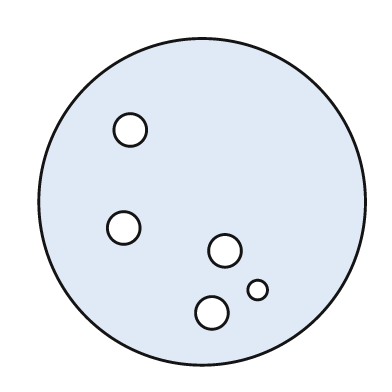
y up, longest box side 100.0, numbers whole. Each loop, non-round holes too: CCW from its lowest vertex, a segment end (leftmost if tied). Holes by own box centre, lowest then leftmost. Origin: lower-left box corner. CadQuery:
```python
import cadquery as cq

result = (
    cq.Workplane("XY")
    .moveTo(50.0, 50.0)
    .circle(50.0)
    .moveTo(53.0, 16.0)
    .circle(5.0)
    .moveTo(67.0, 23.0)
    .circle(3.0)
    .moveTo(57.0, 35.0)
    .circle(5.0)
    .moveTo(26.0, 42.0)
    .circle(5.0)
    .moveTo(28.0, 72.0)
    .circle(5.0)
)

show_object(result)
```